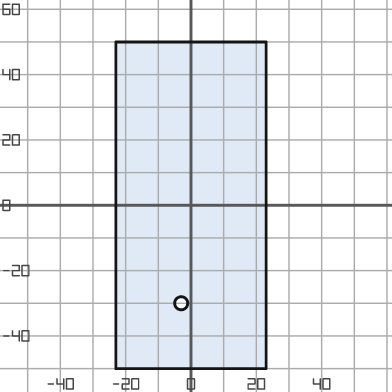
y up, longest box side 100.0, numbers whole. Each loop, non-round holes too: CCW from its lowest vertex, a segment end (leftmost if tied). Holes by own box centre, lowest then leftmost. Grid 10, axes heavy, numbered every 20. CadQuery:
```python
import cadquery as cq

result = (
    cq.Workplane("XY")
    .moveTo(-23.0, -50.0)
    .lineTo(23.0, -50.0)
    .lineTo(23.0, 50.0)
    .lineTo(-23.0, 50.0)
    .close()
    .moveTo(-3.0, -30.0)
    .circle(2.0)
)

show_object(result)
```